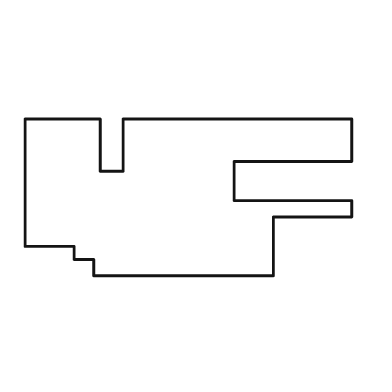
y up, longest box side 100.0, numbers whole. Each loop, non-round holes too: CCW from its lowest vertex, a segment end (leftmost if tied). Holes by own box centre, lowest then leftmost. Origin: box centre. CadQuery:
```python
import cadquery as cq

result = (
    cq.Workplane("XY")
    .moveTo(-29.0, -24.0)
    .lineTo(26.0, -24.0)
    .lineTo(26.0, -6.0)
    .lineTo(50.0, -6.0)
    .lineTo(50.0, -1.0)
    .lineTo(14.0, -1.0)
    .lineTo(14.0, 11.0)
    .lineTo(50.0, 11.0)
    .lineTo(50.0, 24.0)
    .lineTo(-20.0, 24.0)
    .lineTo(-20.0, 8.0)
    .lineTo(-27.0, 8.0)
    .lineTo(-27.0, 24.0)
    .lineTo(-50.0, 24.0)
    .lineTo(-50.0, -15.0)
    .lineTo(-35.0, -15.0)
    .lineTo(-35.0, -19.0)
    .lineTo(-29.0, -19.0)
    .close()
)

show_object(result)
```